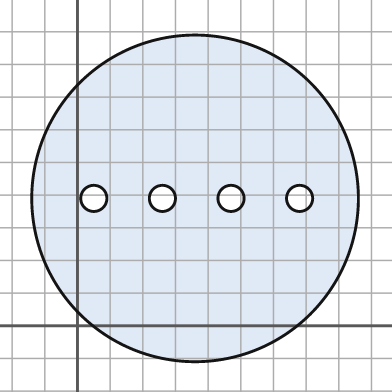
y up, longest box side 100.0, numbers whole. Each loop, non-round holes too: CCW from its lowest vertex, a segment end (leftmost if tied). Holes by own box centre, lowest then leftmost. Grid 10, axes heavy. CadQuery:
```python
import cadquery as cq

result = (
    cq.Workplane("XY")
    .moveTo(36.0, 39.0)
    .circle(50.0)
    .moveTo(5.0, 39.0)
    .circle(4.0)
    .moveTo(26.0, 39.0)
    .circle(4.0)
    .moveTo(47.0, 39.0)
    .circle(4.0)
    .moveTo(68.0, 39.0)
    .circle(4.0)
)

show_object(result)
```